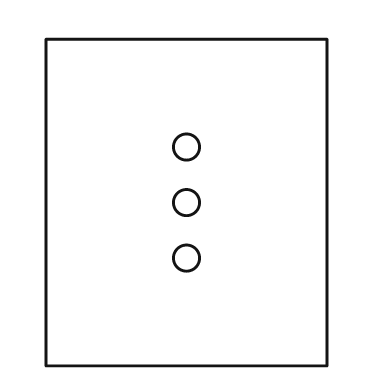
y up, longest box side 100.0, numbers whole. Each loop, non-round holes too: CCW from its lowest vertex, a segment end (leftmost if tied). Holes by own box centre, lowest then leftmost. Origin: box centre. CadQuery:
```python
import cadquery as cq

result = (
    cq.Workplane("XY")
    .moveTo(-43.0, -50.0)
    .lineTo(43.0, -50.0)
    .lineTo(43.0, 50.0)
    .lineTo(-43.0, 50.0)
    .close()
    .moveTo(0.0, -17.0)
    .circle(4.0)
    .moveTo(0.0, 0.0)
    .circle(4.0)
    .moveTo(0.0, 17.0)
    .circle(4.0)
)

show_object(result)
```